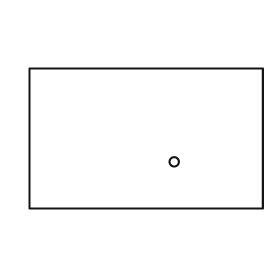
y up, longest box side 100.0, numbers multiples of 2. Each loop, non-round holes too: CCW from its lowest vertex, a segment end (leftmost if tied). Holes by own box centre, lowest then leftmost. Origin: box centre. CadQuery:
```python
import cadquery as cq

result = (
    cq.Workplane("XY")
    .moveTo(-50.0, -30.0)
    .lineTo(50.0, -30.0)
    .lineTo(50.0, 30.0)
    .lineTo(-50.0, 30.0)
    .close()
    .moveTo(12.0, -10.0)
    .circle(2.0)
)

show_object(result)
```